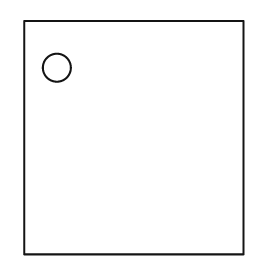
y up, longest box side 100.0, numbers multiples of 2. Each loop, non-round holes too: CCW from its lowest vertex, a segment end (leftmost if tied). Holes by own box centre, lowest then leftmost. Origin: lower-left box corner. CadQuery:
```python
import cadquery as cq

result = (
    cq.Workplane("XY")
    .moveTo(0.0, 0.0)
    .lineTo(94.0, 0.0)
    .lineTo(94.0, 100.0)
    .lineTo(0.0, 100.0)
    .close()
    .moveTo(14.0, 80.0)
    .circle(6.0)
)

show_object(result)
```